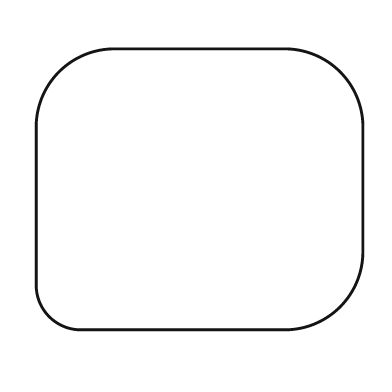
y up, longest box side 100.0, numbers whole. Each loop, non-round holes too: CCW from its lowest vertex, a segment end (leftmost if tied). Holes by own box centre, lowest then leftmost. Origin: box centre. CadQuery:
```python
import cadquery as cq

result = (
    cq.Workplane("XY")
    .moveTo(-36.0, -43.0)
    .lineTo(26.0, -43.0)
    .threePointArc((43.0, -36.0), (50.0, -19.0))
    .lineTo(50.0, 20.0)
    .threePointArc((43.0, 36.0), (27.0, 43.0))
    .lineTo(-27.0, 43.0)
    .threePointArc((-43.0, 36.0), (-50.0, 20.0))
    .lineTo(-50.0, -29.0)
    .threePointArc((-46.0, -39.0), (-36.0, -43.0))
    .close()
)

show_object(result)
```